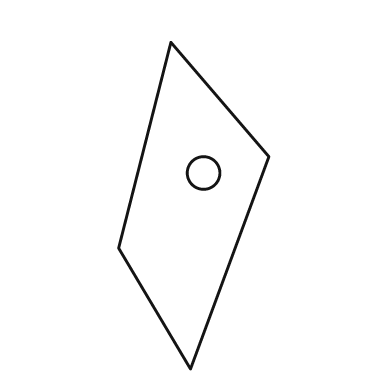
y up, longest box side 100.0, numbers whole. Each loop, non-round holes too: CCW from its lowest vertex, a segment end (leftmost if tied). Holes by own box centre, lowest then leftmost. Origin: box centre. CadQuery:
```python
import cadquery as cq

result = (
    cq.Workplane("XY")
    .moveTo(-1.0, -50.0)
    .lineTo(23.0, 15.0)
    .lineTo(-7.0, 50.0)
    .lineTo(-23.0, -13.0)
    .close()
    .moveTo(3.0, 10.0)
    .circle(5.0)
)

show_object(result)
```